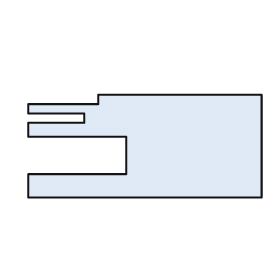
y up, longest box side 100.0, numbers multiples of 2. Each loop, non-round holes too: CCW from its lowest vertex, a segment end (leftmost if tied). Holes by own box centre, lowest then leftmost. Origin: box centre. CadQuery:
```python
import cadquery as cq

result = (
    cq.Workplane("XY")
    .moveTo(-50.0, -22.0)
    .lineTo(50.0, -22.0)
    .lineTo(50.0, 22.0)
    .lineTo(-20.0, 22.0)
    .lineTo(-20.0, 18.0)
    .lineTo(-50.0, 18.0)
    .lineTo(-50.0, 14.0)
    .lineTo(-26.0, 14.0)
    .lineTo(-26.0, 10.0)
    .lineTo(-50.0, 10.0)
    .lineTo(-50.0, 4.0)
    .lineTo(-8.0, 4.0)
    .lineTo(-8.0, -12.0)
    .lineTo(-50.0, -12.0)
    .close()
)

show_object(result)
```